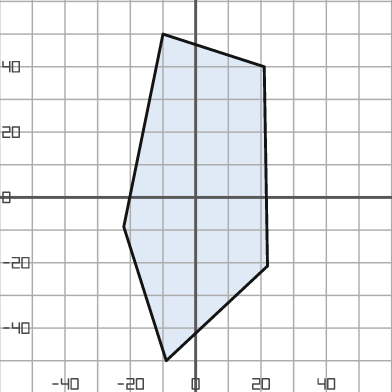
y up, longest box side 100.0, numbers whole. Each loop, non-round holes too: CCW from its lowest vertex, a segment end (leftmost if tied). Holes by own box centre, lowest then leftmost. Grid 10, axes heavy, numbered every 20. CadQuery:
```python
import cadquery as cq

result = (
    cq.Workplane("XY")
    .moveTo(-9.0, -50.0)
    .lineTo(22.0, -21.0)
    .lineTo(21.0, 40.0)
    .lineTo(-10.0, 50.0)
    .lineTo(-22.0, -9.0)
    .close()
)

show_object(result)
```